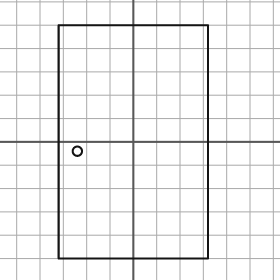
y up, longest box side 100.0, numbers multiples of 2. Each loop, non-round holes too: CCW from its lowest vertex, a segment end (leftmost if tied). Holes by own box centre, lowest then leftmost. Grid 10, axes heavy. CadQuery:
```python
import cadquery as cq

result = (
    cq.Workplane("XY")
    .moveTo(-32.0, -50.0)
    .lineTo(32.0, -50.0)
    .lineTo(32.0, 50.0)
    .lineTo(-32.0, 50.0)
    .close()
    .moveTo(-24.0, -4.0)
    .circle(2.0)
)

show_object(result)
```